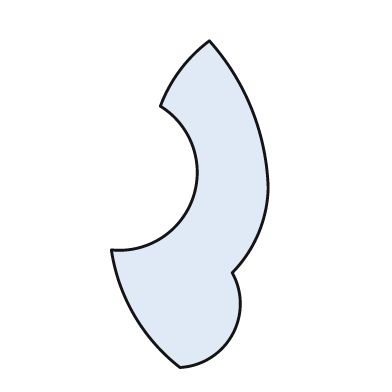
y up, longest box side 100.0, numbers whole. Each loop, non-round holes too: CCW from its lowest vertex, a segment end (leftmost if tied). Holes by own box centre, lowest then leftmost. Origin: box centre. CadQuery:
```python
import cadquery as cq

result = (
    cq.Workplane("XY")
    .moveTo(-3.0, -50.0)
    .threePointArc((13.0, -40.0), (13.0, -21.0))
    .threePointArc((21.0, -9.0), (24.0, 5.0))
    .threePointArc((19.0, 29.0), (6.0, 50.0))
    .threePointArc((-3.0, 41.0), (-9.0, 30.0))
    .threePointArc((1.0, 2.0), (-24.0, -14.0))
    .threePointArc((-17.0, -34.0), (-3.0, -50.0))
    .close()
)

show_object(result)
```